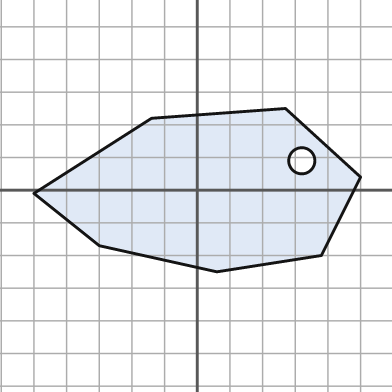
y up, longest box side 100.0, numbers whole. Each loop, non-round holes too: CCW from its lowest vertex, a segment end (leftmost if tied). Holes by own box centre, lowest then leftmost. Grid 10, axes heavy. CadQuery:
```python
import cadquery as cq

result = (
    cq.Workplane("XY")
    .moveTo(6.0, -25.0)
    .lineTo(38.0, -20.0)
    .lineTo(50.0, 4.0)
    .lineTo(27.0, 25.0)
    .lineTo(-14.0, 22.0)
    .lineTo(-50.0, -1.0)
    .lineTo(-30.0, -17.0)
    .close()
    .moveTo(32.0, 9.0)
    .circle(4.0)
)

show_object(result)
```